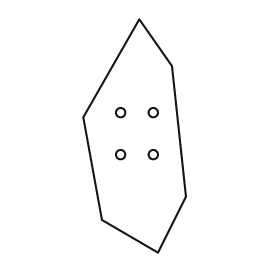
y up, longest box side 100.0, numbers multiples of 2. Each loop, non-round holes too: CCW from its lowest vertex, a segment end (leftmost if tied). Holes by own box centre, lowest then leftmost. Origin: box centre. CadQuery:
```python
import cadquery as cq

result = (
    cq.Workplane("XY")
    .moveTo(10.0, -50.0)
    .lineTo(22.0, -26.0)
    .lineTo(16.0, 30.0)
    .lineTo(2.0, 50.0)
    .lineTo(-22.0, 8.0)
    .lineTo(-14.0, -36.0)
    .close()
    .moveTo(-6.0, -8.0)
    .circle(2.0)
    .moveTo(8.0, -8.0)
    .circle(2.0)
    .moveTo(-6.0, 10.0)
    .circle(2.0)
    .moveTo(8.0, 10.0)
    .circle(2.0)
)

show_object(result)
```